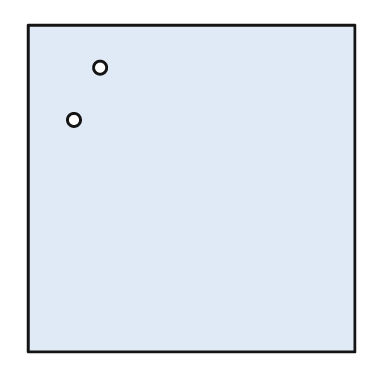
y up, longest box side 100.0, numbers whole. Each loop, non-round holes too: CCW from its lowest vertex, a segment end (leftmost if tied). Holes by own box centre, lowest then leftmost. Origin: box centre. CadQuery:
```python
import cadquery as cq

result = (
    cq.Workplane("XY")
    .moveTo(-50.0, -50.0)
    .lineTo(50.0, -50.0)
    .lineTo(50.0, 50.0)
    .lineTo(-50.0, 50.0)
    .close()
    .moveTo(-36.0, 21.0)
    .circle(2.0)
    .moveTo(-28.0, 37.0)
    .circle(2.0)
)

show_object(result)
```